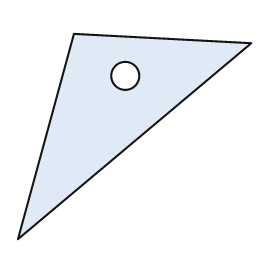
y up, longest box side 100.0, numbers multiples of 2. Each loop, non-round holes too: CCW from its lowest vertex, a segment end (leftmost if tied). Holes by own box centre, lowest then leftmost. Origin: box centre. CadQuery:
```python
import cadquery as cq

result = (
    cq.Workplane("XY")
    .moveTo(-50.0, -44.0)
    .lineTo(50.0, 40.0)
    .lineTo(-26.0, 44.0)
    .close()
    .moveTo(-4.0, 26.0)
    .circle(6.0)
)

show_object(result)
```